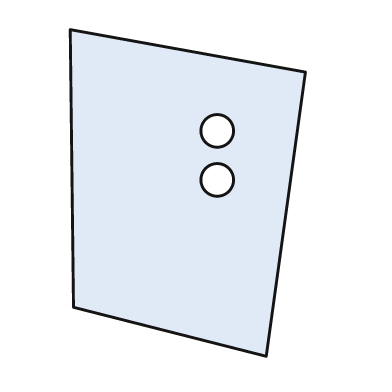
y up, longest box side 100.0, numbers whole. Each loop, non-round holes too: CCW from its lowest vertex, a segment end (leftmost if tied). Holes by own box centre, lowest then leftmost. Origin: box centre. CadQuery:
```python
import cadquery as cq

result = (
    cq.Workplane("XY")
    .moveTo(24.0, -50.0)
    .lineTo(36.0, 37.0)
    .lineTo(-36.0, 50.0)
    .lineTo(-35.0, -35.0)
    .close()
    .moveTo(9.0, 4.0)
    .circle(5.0)
    .moveTo(9.0, 19.0)
    .circle(5.0)
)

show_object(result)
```